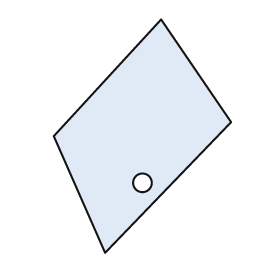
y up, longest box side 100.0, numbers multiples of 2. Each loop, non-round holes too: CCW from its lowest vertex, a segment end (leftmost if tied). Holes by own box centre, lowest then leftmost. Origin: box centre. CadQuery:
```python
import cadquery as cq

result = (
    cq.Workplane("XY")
    .moveTo(-16.0, -50.0)
    .lineTo(38.0, 6.0)
    .lineTo(8.0, 50.0)
    .lineTo(-38.0, 0.0)
    .close()
    .moveTo(0.0, -20.0)
    .circle(4.0)
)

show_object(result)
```